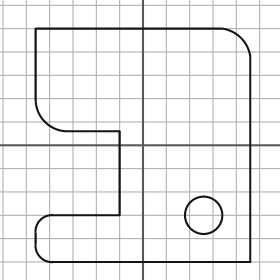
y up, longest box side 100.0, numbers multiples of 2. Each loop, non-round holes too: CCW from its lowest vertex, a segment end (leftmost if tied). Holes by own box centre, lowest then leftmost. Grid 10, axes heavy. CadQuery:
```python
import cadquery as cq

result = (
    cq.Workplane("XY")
    .moveTo(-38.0, -50.0)
    .lineTo(46.0, -50.0)
    .lineTo(46.0, 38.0)
    .threePointArc((42.0, 46.0), (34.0, 50.0))
    .lineTo(-46.0, 50.0)
    .lineTo(-46.0, 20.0)
    .threePointArc((-42.0, 10.0), (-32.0, 6.0))
    .lineTo(-10.0, 6.0)
    .lineTo(-10.0, -30.0)
    .lineTo(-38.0, -30.0)
    .threePointArc((-44.0, -32.0), (-46.0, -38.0))
    .lineTo(-46.0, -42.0)
    .threePointArc((-44.0, -48.0), (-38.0, -50.0))
    .close()
    .moveTo(26.0, -30.0)
    .circle(8.0)
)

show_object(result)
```